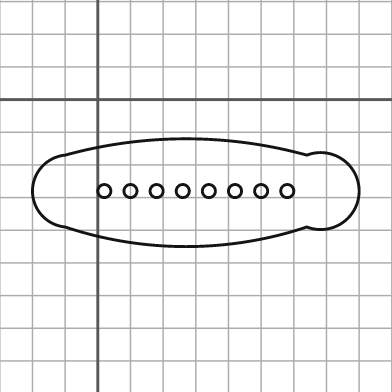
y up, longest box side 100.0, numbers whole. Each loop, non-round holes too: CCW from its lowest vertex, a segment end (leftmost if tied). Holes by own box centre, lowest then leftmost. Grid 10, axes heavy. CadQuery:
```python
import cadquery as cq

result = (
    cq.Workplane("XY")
    .moveTo(-10.0, -39.0)
    .threePointArc((27.0, -45.0), (64.0, -39.0))
    .threePointArc((80.0, -28.0), (64.0, -17.0))
    .threePointArc((27.0, -12.0), (-10.0, -17.0))
    .threePointArc((-20.0, -28.0), (-10.0, -39.0))
    .close()
    .moveTo(2.0, -28.0)
    .circle(2.0)
    .moveTo(10.0, -28.0)
    .circle(2.0)
    .moveTo(18.0, -28.0)
    .circle(2.0)
    .moveTo(26.0, -28.0)
    .circle(2.0)
    .moveTo(34.0, -28.0)
    .circle(2.0)
    .moveTo(42.0, -28.0)
    .circle(2.0)
    .moveTo(50.0, -28.0)
    .circle(2.0)
    .moveTo(58.0, -28.0)
    .circle(2.0)
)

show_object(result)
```